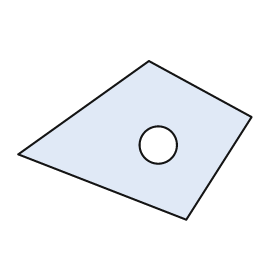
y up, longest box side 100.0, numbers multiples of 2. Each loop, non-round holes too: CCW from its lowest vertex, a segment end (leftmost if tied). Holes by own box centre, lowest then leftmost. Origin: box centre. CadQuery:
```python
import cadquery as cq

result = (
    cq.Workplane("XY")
    .moveTo(22.0, -34.0)
    .lineTo(50.0, 10.0)
    .lineTo(6.0, 34.0)
    .lineTo(-50.0, -6.0)
    .close()
    .moveTo(10.0, -2.0)
    .circle(8.0)
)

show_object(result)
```